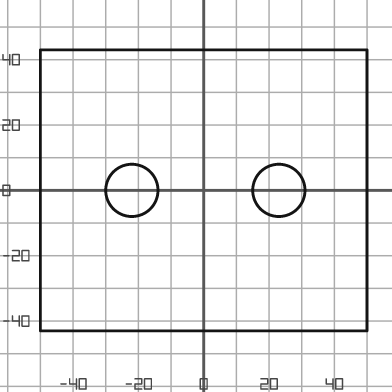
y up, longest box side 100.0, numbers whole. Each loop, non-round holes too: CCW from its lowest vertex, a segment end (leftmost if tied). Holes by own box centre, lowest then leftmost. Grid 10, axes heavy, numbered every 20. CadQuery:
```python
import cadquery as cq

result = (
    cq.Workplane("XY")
    .moveTo(-50.0, -43.0)
    .lineTo(50.0, -43.0)
    .lineTo(50.0, 43.0)
    .lineTo(-50.0, 43.0)
    .close()
    .moveTo(-22.0, 0.0)
    .circle(8.0)
    .moveTo(23.0, 0.0)
    .circle(8.0)
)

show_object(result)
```